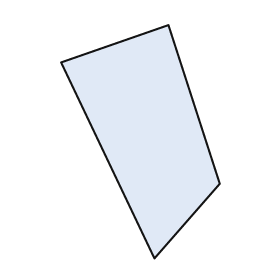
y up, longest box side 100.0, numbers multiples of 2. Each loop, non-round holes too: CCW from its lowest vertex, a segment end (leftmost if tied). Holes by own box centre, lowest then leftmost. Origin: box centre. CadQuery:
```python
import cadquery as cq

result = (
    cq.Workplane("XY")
    .moveTo(6.0, -50.0)
    .lineTo(34.0, -18.0)
    .lineTo(12.0, 50.0)
    .lineTo(-34.0, 34.0)
    .close()
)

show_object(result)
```